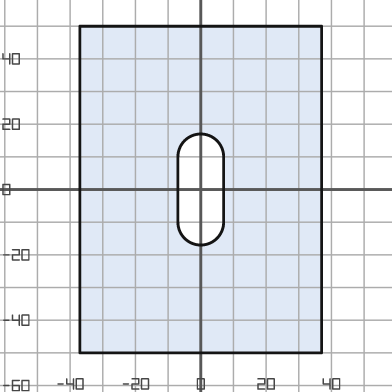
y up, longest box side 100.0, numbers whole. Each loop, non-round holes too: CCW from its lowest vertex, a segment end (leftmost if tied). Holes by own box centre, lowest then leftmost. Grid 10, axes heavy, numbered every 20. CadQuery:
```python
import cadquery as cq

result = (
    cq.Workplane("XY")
    .moveTo(-37.0, -50.0)
    .lineTo(37.0, -50.0)
    .lineTo(37.0, 50.0)
    .lineTo(-37.0, 50.0)
    .close()
    .moveTo(-7.0, -10.0)
    .threePointArc((0.0, -17.0), (7.0, -10.0))
    .lineTo(7.0, 10.0)
    .threePointArc((0.0, 17.0), (-7.0, 10.0))
    .close()
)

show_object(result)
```